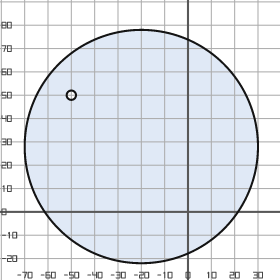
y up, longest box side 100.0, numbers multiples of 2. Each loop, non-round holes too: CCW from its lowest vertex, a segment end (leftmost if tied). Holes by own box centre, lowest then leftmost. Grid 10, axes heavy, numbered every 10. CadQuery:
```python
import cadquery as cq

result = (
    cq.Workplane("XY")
    .moveTo(-20.0, 28.0)
    .circle(50.0)
    .moveTo(-50.0, 50.0)
    .circle(2.0)
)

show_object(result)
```